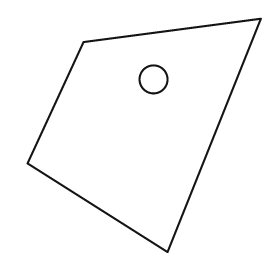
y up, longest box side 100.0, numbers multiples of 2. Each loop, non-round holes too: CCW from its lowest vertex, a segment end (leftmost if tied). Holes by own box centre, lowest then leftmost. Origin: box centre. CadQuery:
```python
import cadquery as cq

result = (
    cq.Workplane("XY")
    .moveTo(10.0, -50.0)
    .lineTo(50.0, 50.0)
    .lineTo(-26.0, 40.0)
    .lineTo(-50.0, -12.0)
    .close()
    .moveTo(4.0, 24.0)
    .circle(6.0)
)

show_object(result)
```